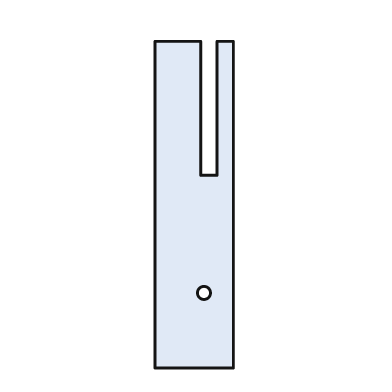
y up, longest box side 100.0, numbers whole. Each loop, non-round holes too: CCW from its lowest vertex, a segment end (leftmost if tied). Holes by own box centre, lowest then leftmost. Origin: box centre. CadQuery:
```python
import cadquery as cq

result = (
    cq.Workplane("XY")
    .moveTo(-12.0, -50.0)
    .lineTo(12.0, -50.0)
    .lineTo(12.0, 50.0)
    .lineTo(7.0, 50.0)
    .lineTo(7.0, 9.0)
    .lineTo(2.0, 9.0)
    .lineTo(2.0, 50.0)
    .lineTo(-12.0, 50.0)
    .close()
    .moveTo(3.0, -27.0)
    .circle(2.0)
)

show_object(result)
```